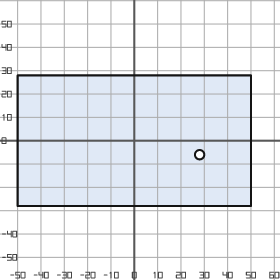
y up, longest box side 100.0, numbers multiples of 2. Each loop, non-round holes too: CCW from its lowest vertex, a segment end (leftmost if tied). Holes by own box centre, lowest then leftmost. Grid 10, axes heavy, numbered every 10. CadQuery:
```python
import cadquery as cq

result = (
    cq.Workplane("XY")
    .moveTo(-50.0, -28.0)
    .lineTo(50.0, -28.0)
    .lineTo(50.0, 28.0)
    .lineTo(-50.0, 28.0)
    .close()
    .moveTo(28.0, -6.0)
    .circle(2.0)
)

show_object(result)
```